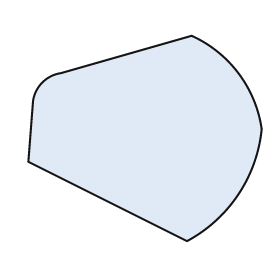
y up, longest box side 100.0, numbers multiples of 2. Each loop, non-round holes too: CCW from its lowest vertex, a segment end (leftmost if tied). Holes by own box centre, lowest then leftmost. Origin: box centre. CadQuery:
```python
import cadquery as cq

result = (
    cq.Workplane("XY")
    .moveTo(18.0, -44.0)
    .threePointArc((40.0, -24.0), (50.0, 4.0))
    .threePointArc((40.0, 28.0), (20.0, 44.0))
    .lineTo(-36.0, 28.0)
    .threePointArc((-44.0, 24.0), (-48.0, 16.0))
    .lineTo(-50.0, -10.0)
    .close()
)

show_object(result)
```